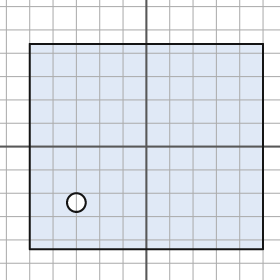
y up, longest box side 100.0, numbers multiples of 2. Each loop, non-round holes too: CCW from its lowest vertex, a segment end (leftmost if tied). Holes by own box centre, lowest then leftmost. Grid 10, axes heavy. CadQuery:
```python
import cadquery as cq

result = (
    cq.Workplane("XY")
    .moveTo(-50.0, -44.0)
    .lineTo(50.0, -44.0)
    .lineTo(50.0, 44.0)
    .lineTo(-50.0, 44.0)
    .close()
    .moveTo(-30.0, -24.0)
    .circle(4.0)
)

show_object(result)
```